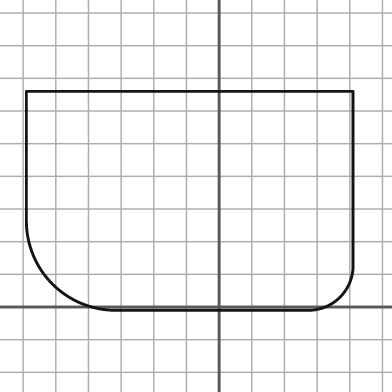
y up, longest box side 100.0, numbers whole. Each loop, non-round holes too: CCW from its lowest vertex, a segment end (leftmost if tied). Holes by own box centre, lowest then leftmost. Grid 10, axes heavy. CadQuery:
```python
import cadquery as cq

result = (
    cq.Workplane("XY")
    .moveTo(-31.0, -1.0)
    .lineTo(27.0, -1.0)
    .threePointArc((37.0, 3.0), (41.0, 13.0))
    .lineTo(41.0, 66.0)
    .lineTo(-59.0, 66.0)
    .lineTo(-59.0, 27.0)
    .threePointArc((-51.0, 7.0), (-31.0, -1.0))
    .close()
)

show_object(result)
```